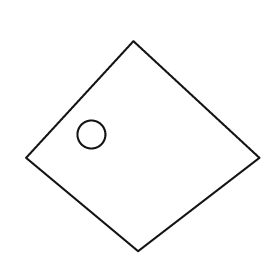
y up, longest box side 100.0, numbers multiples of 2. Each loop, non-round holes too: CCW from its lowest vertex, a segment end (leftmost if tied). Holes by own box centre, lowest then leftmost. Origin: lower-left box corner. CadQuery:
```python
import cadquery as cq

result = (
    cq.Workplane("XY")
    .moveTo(48.0, 0.0)
    .lineTo(100.0, 40.0)
    .lineTo(46.0, 90.0)
    .lineTo(0.0, 40.0)
    .close()
    .moveTo(28.0, 50.0)
    .circle(6.0)
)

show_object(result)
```